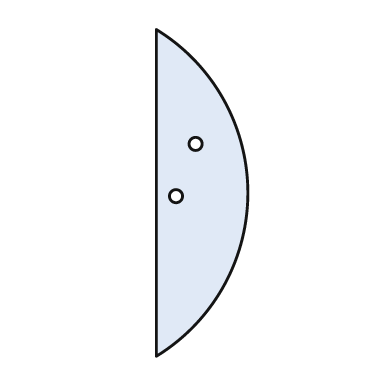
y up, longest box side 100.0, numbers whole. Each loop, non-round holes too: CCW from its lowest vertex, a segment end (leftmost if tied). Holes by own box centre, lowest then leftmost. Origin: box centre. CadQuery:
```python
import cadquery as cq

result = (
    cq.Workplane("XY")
    .moveTo(-14.0, -50.0)
    .threePointArc((14.0, 0.0), (-14.0, 50.0))
    .close()
    .moveTo(-8.0, -1.0)
    .circle(2.0)
    .moveTo(-2.0, 15.0)
    .circle(2.0)
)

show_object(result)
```